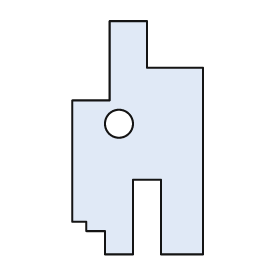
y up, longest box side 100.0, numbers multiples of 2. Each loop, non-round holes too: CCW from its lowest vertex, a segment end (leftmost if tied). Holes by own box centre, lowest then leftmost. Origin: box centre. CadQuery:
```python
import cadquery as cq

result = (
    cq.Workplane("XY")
    .moveTo(-14.0, -50.0)
    .lineTo(-2.0, -50.0)
    .lineTo(-2.0, -18.0)
    .lineTo(10.0, -18.0)
    .lineTo(10.0, -50.0)
    .lineTo(28.0, -50.0)
    .lineTo(28.0, 30.0)
    .lineTo(4.0, 30.0)
    .lineTo(4.0, 50.0)
    .lineTo(-12.0, 50.0)
    .lineTo(-12.0, 16.0)
    .lineTo(-28.0, 16.0)
    .lineTo(-28.0, -36.0)
    .lineTo(-22.0, -36.0)
    .lineTo(-22.0, -40.0)
    .lineTo(-14.0, -40.0)
    .close()
    .moveTo(-8.0, 6.0)
    .circle(6.0)
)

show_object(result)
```